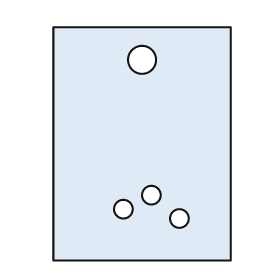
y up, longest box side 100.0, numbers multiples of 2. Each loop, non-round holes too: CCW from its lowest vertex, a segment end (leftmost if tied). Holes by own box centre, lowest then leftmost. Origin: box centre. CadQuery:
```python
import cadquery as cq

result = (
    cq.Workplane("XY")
    .moveTo(-38.0, -50.0)
    .lineTo(38.0, -50.0)
    .lineTo(38.0, 50.0)
    .lineTo(-38.0, 50.0)
    .close()
    .moveTo(16.0, -32.0)
    .circle(4.0)
    .moveTo(-8.0, -28.0)
    .circle(4.0)
    .moveTo(4.0, -22.0)
    .circle(4.0)
    .moveTo(0.0, 36.0)
    .circle(6.0)
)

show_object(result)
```